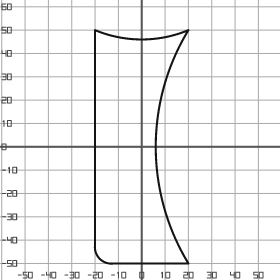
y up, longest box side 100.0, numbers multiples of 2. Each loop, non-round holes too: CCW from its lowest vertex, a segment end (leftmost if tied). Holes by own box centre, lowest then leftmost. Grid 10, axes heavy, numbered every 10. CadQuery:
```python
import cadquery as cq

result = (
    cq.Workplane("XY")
    .moveTo(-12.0, -50.0)
    .lineTo(20.0, -50.0)
    .threePointArc((6.0, 0.0), (20.0, 50.0))
    .threePointArc((0.0, 46.0), (-20.0, 50.0))
    .lineTo(-20.0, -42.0)
    .threePointArc((-18.0, -48.0), (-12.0, -50.0))
    .close()
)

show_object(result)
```